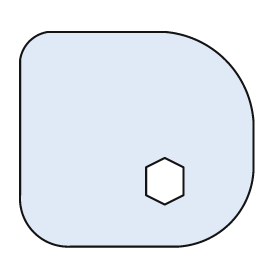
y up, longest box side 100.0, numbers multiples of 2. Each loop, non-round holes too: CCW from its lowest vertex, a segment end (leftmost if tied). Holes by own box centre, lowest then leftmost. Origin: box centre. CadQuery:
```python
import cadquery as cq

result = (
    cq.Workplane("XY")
    .moveTo(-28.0, -46.0)
    .lineTo(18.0, -46.0)
    .threePointArc((40.0, -36.0), (50.0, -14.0))
    .lineTo(50.0, 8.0)
    .threePointArc((38.0, 34.0), (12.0, 46.0))
    .lineTo(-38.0, 46.0)
    .threePointArc((-46.0, 42.0), (-50.0, 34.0))
    .lineTo(-50.0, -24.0)
    .threePointArc((-44.0, -40.0), (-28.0, -46.0))
    .close()
    .moveTo(12.0, -28.0)
    .lineTo(20.0, -24.0)
    .lineTo(20.0, -12.0)
    .lineTo(12.0, -8.0)
    .lineTo(4.0, -12.0)
    .lineTo(4.0, -24.0)
    .close()
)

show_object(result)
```